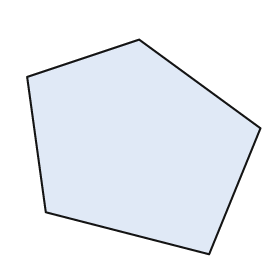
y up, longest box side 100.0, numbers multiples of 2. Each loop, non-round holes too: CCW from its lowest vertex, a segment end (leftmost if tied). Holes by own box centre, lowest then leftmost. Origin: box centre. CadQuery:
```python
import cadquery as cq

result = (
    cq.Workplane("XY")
    .moveTo(28.0, -46.0)
    .lineTo(50.0, 8.0)
    .lineTo(-2.0, 46.0)
    .lineTo(-50.0, 30.0)
    .lineTo(-42.0, -28.0)
    .close()
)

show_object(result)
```